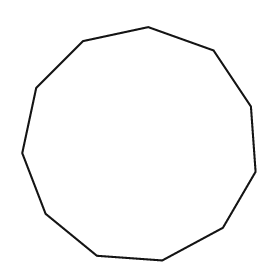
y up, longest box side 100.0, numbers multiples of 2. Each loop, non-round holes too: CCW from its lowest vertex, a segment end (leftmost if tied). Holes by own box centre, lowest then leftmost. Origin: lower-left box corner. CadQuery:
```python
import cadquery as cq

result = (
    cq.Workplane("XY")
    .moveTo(60.0, 0.0)
    .lineTo(86.0, 14.0)
    .lineTo(100.0, 38.0)
    .lineTo(98.0, 66.0)
    .lineTo(82.0, 90.0)
    .lineTo(54.0, 100.0)
    .lineTo(26.0, 94.0)
    .lineTo(6.0, 74.0)
    .lineTo(0.0, 46.0)
    .lineTo(10.0, 20.0)
    .lineTo(32.0, 2.0)
    .close()
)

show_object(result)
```